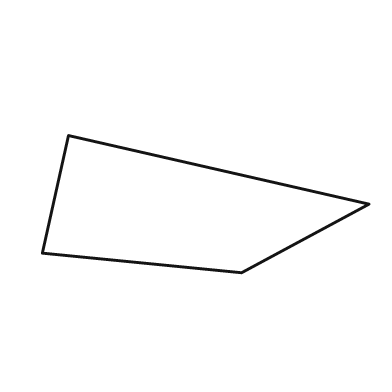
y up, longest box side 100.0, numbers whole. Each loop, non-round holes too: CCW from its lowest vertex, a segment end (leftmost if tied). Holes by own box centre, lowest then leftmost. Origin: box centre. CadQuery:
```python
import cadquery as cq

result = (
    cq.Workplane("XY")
    .moveTo(11.0, -21.0)
    .lineTo(50.0, 0.0)
    .lineTo(-42.0, 21.0)
    .lineTo(-50.0, -15.0)
    .close()
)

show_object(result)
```